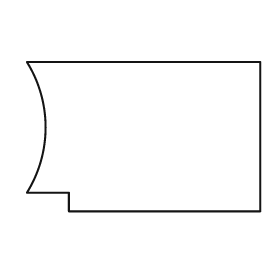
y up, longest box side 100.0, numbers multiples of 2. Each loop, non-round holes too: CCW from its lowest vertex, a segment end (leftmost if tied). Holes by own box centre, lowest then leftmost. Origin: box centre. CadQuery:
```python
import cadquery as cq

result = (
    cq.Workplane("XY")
    .moveTo(-32.0, -32.0)
    .lineTo(50.0, -32.0)
    .lineTo(50.0, 32.0)
    .lineTo(-50.0, 32.0)
    .threePointArc((-42.0, 4.0), (-50.0, -24.0))
    .lineTo(-32.0, -24.0)
    .close()
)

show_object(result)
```